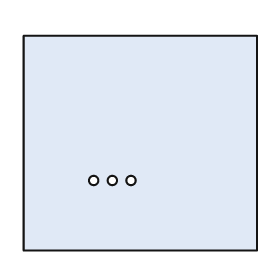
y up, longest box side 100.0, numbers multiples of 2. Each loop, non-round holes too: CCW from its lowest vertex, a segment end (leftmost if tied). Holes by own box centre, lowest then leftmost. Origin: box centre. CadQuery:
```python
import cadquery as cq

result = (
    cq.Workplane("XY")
    .moveTo(-50.0, -46.0)
    .lineTo(50.0, -46.0)
    .lineTo(50.0, 46.0)
    .lineTo(-50.0, 46.0)
    .close()
    .moveTo(-20.0, -16.0)
    .circle(2.0)
    .moveTo(-12.0, -16.0)
    .circle(2.0)
    .moveTo(-4.0, -16.0)
    .circle(2.0)
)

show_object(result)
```